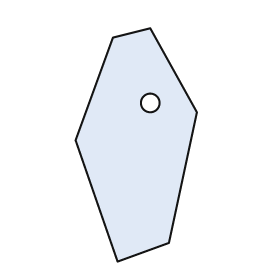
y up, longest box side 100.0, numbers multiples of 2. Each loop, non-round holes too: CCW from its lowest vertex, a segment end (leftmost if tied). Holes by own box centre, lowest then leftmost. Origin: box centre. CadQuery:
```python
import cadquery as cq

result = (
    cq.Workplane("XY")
    .moveTo(-8.0, -50.0)
    .lineTo(14.0, -42.0)
    .lineTo(26.0, 14.0)
    .lineTo(6.0, 50.0)
    .lineTo(-10.0, 46.0)
    .lineTo(-26.0, 2.0)
    .close()
    .moveTo(6.0, 18.0)
    .circle(4.0)
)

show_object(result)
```